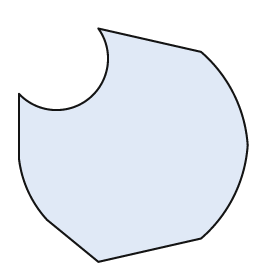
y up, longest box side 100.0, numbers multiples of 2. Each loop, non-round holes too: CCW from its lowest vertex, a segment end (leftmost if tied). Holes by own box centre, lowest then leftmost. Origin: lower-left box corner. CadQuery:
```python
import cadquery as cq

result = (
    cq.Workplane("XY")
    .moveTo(34.0, 0.0)
    .lineTo(78.0, 10.0)
    .threePointArc((92.0, 28.0), (98.0, 50.0))
    .threePointArc((92.0, 72.0), (78.0, 90.0))
    .lineTo(34.0, 100.0)
    .threePointArc((30.0, 70.0), (0.0, 72.0))
    .lineTo(0.0, 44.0)
    .threePointArc((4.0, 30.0), (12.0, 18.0))
    .close()
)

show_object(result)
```